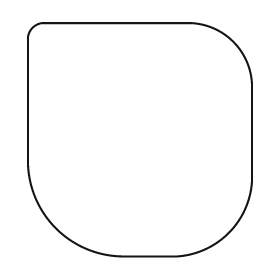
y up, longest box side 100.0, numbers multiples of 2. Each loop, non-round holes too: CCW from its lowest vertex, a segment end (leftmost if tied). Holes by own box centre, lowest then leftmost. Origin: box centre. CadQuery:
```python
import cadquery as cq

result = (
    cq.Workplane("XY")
    .moveTo(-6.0, -50.0)
    .lineTo(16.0, -50.0)
    .threePointArc((38.0, -40.0), (48.0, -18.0))
    .lineTo(48.0, 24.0)
    .threePointArc((40.0, 42.0), (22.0, 50.0))
    .lineTo(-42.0, 50.0)
    .threePointArc((-46.0, 48.0), (-48.0, 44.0))
    .lineTo(-48.0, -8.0)
    .threePointArc((-36.0, -38.0), (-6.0, -50.0))
    .close()
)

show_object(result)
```